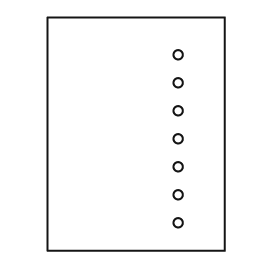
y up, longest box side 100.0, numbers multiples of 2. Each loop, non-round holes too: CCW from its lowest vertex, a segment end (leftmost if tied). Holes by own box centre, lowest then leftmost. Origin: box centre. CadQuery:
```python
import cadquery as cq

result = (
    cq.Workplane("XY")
    .moveTo(-38.0, -50.0)
    .lineTo(38.0, -50.0)
    .lineTo(38.0, 50.0)
    .lineTo(-38.0, 50.0)
    .close()
    .moveTo(18.0, -38.0)
    .circle(2.0)
    .moveTo(18.0, -26.0)
    .circle(2.0)
    .moveTo(18.0, -14.0)
    .circle(2.0)
    .moveTo(18.0, -2.0)
    .circle(2.0)
    .moveTo(18.0, 10.0)
    .circle(2.0)
    .moveTo(18.0, 22.0)
    .circle(2.0)
    .moveTo(18.0, 34.0)
    .circle(2.0)
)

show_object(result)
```